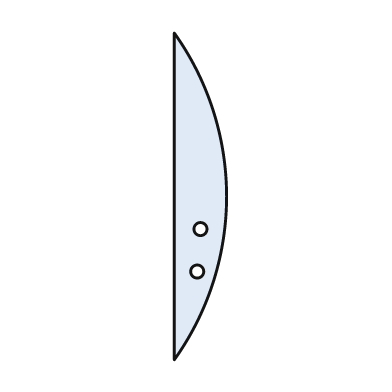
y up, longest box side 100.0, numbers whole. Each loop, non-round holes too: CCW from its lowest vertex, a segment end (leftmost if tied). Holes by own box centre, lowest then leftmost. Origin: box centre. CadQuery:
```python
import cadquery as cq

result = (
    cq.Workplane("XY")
    .moveTo(-8.0, -50.0)
    .threePointArc((8.0, 0.0), (-8.0, 50.0))
    .close()
    .moveTo(-1.0, -23.0)
    .circle(2.0)
    .moveTo(0.0, -10.0)
    .circle(2.0)
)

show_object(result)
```